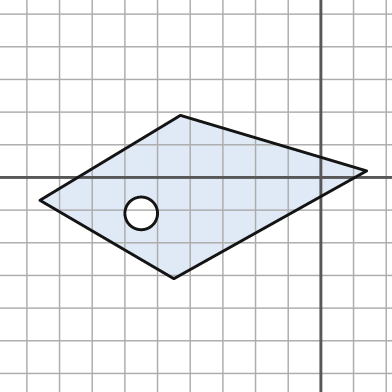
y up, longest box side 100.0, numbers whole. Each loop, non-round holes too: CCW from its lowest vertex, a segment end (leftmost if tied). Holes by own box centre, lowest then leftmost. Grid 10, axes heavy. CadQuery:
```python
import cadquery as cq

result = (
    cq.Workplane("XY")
    .moveTo(-45.0, -31.0)
    .lineTo(14.0, 2.0)
    .lineTo(-43.0, 19.0)
    .lineTo(-86.0, -7.0)
    .close()
    .moveTo(-55.0, -11.0)
    .circle(5.0)
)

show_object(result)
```